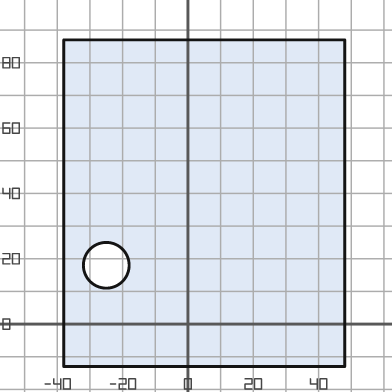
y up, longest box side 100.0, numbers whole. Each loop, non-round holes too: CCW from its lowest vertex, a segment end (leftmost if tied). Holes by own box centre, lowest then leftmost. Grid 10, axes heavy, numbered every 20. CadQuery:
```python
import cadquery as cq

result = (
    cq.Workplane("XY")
    .moveTo(-38.0, -13.0)
    .lineTo(48.0, -13.0)
    .lineTo(48.0, 87.0)
    .lineTo(-38.0, 87.0)
    .close()
    .moveTo(-25.0, 18.0)
    .circle(7.0)
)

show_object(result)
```